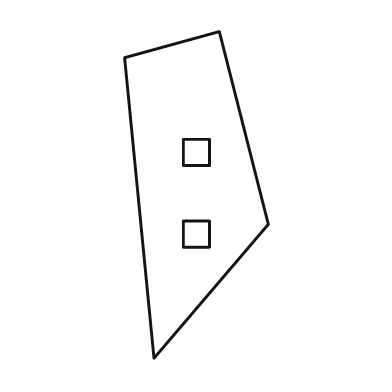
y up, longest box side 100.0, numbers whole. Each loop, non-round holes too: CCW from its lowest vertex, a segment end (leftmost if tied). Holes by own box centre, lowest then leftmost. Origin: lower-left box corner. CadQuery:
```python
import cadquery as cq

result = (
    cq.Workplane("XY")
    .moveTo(9.0, 0.0)
    .lineTo(44.0, 41.0)
    .lineTo(29.0, 100.0)
    .lineTo(0.0, 92.0)
    .close()
    .moveTo(18.0, 34.0)
    .lineTo(26.0, 34.0)
    .lineTo(26.0, 42.0)
    .lineTo(18.0, 42.0)
    .close()
    .moveTo(18.0, 59.0)
    .lineTo(26.0, 59.0)
    .lineTo(26.0, 67.0)
    .lineTo(18.0, 67.0)
    .close()
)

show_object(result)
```